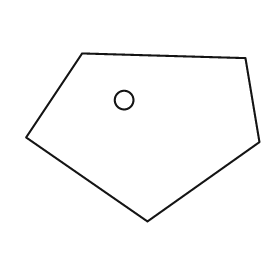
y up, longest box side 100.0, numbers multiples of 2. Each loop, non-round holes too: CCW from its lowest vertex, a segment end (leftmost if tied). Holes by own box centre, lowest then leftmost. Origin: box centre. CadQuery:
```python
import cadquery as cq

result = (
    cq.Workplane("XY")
    .moveTo(2.0, -36.0)
    .lineTo(50.0, -2.0)
    .lineTo(44.0, 34.0)
    .lineTo(-26.0, 36.0)
    .lineTo(-50.0, 0.0)
    .close()
    .moveTo(-8.0, 16.0)
    .circle(4.0)
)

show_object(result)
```